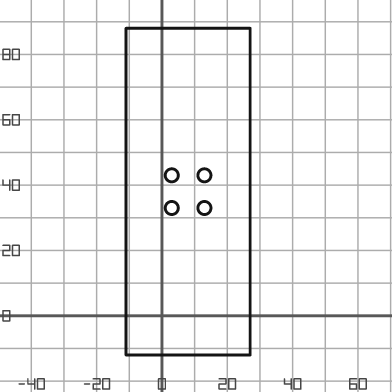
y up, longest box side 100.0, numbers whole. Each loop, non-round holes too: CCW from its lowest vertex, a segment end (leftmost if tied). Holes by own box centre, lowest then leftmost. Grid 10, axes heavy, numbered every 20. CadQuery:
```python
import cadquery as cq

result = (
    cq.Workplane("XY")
    .moveTo(-11.0, -12.0)
    .lineTo(27.0, -12.0)
    .lineTo(27.0, 88.0)
    .lineTo(-11.0, 88.0)
    .close()
    .moveTo(3.0, 33.0)
    .circle(2.0)
    .moveTo(13.0, 33.0)
    .circle(2.0)
    .moveTo(3.0, 43.0)
    .circle(2.0)
    .moveTo(13.0, 43.0)
    .circle(2.0)
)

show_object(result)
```